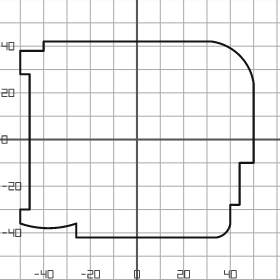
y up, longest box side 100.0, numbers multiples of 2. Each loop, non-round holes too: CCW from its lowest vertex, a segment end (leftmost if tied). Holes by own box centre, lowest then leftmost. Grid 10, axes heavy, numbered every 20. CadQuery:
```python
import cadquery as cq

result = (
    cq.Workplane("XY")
    .moveTo(-26.0, -42.0)
    .lineTo(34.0, -42.0)
    .threePointArc((38.0, -40.0), (40.0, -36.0))
    .lineTo(40.0, -28.0)
    .lineTo(44.0, -28.0)
    .lineTo(44.0, -10.0)
    .lineTo(50.0, -10.0)
    .lineTo(50.0, 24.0)
    .threePointArc((44.0, 36.0), (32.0, 42.0))
    .lineTo(-40.0, 42.0)
    .lineTo(-40.0, 38.0)
    .lineTo(-50.0, 38.0)
    .lineTo(-50.0, 28.0)
    .lineTo(-46.0, 28.0)
    .lineTo(-46.0, -30.0)
    .lineTo(-50.0, -30.0)
    .lineTo(-50.0, -36.0)
    .threePointArc((-38.0, -38.0), (-26.0, -36.0))
    .close()
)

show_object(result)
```